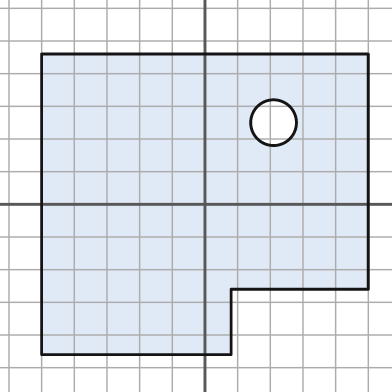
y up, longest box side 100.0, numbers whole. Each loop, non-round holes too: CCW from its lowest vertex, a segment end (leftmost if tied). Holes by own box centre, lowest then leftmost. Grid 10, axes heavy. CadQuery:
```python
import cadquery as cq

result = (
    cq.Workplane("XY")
    .moveTo(-50.0, -46.0)
    .lineTo(8.0, -46.0)
    .lineTo(8.0, -26.0)
    .lineTo(50.0, -26.0)
    .lineTo(50.0, 46.0)
    .lineTo(-50.0, 46.0)
    .close()
    .moveTo(21.0, 25.0)
    .circle(7.0)
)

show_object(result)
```